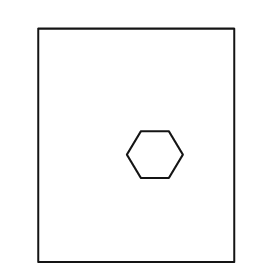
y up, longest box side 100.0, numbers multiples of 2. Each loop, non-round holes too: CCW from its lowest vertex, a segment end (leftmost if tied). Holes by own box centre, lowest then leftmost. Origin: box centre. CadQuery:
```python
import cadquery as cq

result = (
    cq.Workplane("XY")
    .moveTo(-42.0, -50.0)
    .lineTo(42.0, -50.0)
    .lineTo(42.0, 50.0)
    .lineTo(-42.0, 50.0)
    .close()
    .moveTo(2.0, -14.0)
    .lineTo(14.0, -14.0)
    .lineTo(20.0, -4.0)
    .lineTo(14.0, 6.0)
    .lineTo(2.0, 6.0)
    .lineTo(-4.0, -4.0)
    .close()
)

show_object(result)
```